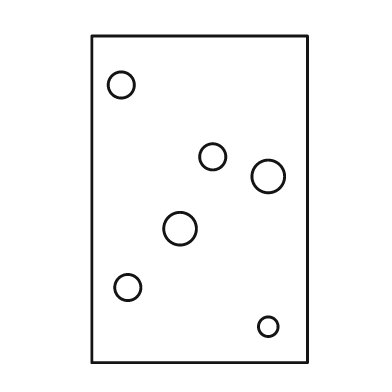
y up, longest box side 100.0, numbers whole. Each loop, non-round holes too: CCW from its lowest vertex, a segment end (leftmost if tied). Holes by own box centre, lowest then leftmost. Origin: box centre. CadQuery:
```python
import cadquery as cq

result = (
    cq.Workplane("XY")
    .moveTo(-33.0, -50.0)
    .lineTo(33.0, -50.0)
    .lineTo(33.0, 50.0)
    .lineTo(-33.0, 50.0)
    .close()
    .moveTo(21.0, -39.0)
    .circle(3.0)
    .moveTo(-22.0, -27.0)
    .circle(4.0)
    .moveTo(-6.0, -9.0)
    .circle(5.0)
    .moveTo(21.0, 7.0)
    .circle(5.0)
    .moveTo(4.0, 13.0)
    .circle(4.0)
    .moveTo(-24.0, 35.0)
    .circle(4.0)
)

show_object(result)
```